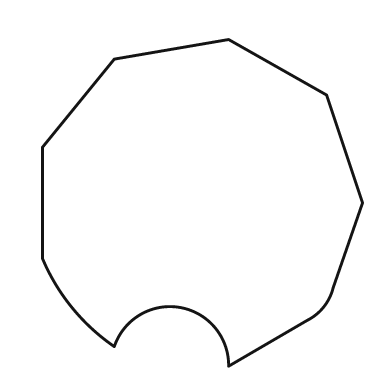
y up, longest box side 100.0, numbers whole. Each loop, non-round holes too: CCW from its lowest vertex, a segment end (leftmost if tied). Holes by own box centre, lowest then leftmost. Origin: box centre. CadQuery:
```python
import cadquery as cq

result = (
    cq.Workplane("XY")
    .moveTo(8.0, -50.0)
    .lineTo(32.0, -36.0)
    .threePointArc((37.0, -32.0), (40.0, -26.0))
    .lineTo(49.0, 0.0)
    .lineTo(38.0, 33.0)
    .lineTo(8.0, 50.0)
    .lineTo(-27.0, 44.0)
    .lineTo(-49.0, 17.0)
    .lineTo(-49.0, -17.0)
    .threePointArc((-40.0, -32.0), (-27.0, -44.0))
    .threePointArc((-7.0, -32.0), (8.0, -50.0))
    .close()
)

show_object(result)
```